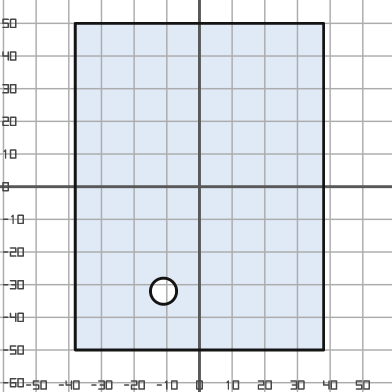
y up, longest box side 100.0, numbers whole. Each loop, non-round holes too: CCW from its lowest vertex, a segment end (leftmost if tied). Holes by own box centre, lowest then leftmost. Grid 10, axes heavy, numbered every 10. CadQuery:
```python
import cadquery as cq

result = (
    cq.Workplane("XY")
    .moveTo(-38.0, -50.0)
    .lineTo(38.0, -50.0)
    .lineTo(38.0, 50.0)
    .lineTo(-38.0, 50.0)
    .close()
    .moveTo(-11.0, -32.0)
    .circle(4.0)
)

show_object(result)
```